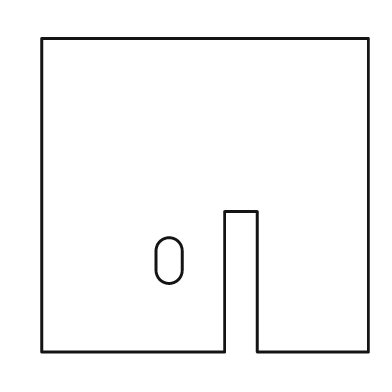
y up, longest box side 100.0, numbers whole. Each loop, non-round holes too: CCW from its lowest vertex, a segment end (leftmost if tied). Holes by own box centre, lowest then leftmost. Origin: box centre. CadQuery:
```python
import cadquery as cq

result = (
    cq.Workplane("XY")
    .moveTo(-50.0, -48.0)
    .lineTo(6.0, -48.0)
    .lineTo(6.0, -5.0)
    .lineTo(16.0, -5.0)
    .lineTo(16.0, -48.0)
    .lineTo(50.0, -48.0)
    .lineTo(50.0, 48.0)
    .lineTo(-50.0, 48.0)
    .close()
    .moveTo(-15.0, -23.0)
    .threePointArc((-11.0, -27.0), (-7.0, -23.0))
    .lineTo(-7.0, -17.0)
    .threePointArc((-11.0, -13.0), (-15.0, -17.0))
    .close()
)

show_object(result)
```